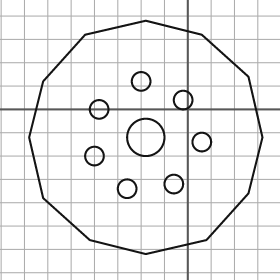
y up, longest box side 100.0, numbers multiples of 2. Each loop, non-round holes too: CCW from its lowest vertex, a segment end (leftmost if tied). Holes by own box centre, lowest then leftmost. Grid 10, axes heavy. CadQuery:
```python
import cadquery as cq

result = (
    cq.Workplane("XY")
    .moveTo(-18.0, -62.0)
    .lineTo(8.0, -56.0)
    .lineTo(26.0, -36.0)
    .lineTo(32.0, -12.0)
    .lineTo(26.0, 14.0)
    .lineTo(6.0, 32.0)
    .lineTo(-18.0, 38.0)
    .lineTo(-44.0, 32.0)
    .lineTo(-62.0, 12.0)
    .lineTo(-68.0, -12.0)
    .lineTo(-62.0, -38.0)
    .lineTo(-42.0, -56.0)
    .close()
    .moveTo(-26.0, -34.0)
    .circle(4.0)
    .moveTo(-6.0, -32.0)
    .circle(4.0)
    .moveTo(-40.0, -20.0)
    .circle(4.0)
    .moveTo(6.0, -14.0)
    .circle(4.0)
    .moveTo(-18.0, -12.0)
    .circle(8.0)
    .moveTo(-38.0, 0.0)
    .circle(4.0)
    .moveTo(-2.0, 4.0)
    .circle(4.0)
    .moveTo(-20.0, 12.0)
    .circle(4.0)
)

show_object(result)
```